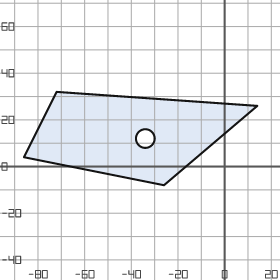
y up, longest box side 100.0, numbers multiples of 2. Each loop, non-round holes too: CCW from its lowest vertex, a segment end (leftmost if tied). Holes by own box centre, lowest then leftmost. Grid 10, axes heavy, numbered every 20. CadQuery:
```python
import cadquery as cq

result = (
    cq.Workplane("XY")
    .moveTo(-26.0, -8.0)
    .lineTo(14.0, 26.0)
    .lineTo(-72.0, 32.0)
    .lineTo(-86.0, 4.0)
    .close()
    .moveTo(-34.0, 12.0)
    .circle(4.0)
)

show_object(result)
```